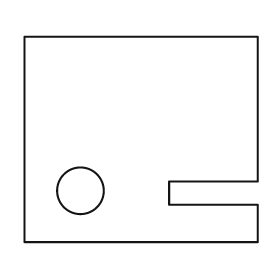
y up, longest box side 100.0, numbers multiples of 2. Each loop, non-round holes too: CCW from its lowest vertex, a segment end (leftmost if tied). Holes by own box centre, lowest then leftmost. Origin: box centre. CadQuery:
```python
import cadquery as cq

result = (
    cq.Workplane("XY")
    .moveTo(-50.0, -44.0)
    .lineTo(50.0, -44.0)
    .lineTo(50.0, -28.0)
    .lineTo(12.0, -28.0)
    .lineTo(12.0, -18.0)
    .lineTo(50.0, -18.0)
    .lineTo(50.0, 44.0)
    .lineTo(-50.0, 44.0)
    .close()
    .moveTo(-26.0, -22.0)
    .circle(10.0)
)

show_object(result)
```